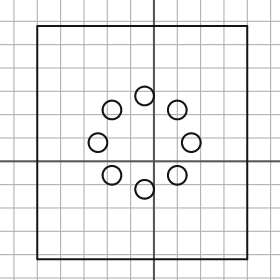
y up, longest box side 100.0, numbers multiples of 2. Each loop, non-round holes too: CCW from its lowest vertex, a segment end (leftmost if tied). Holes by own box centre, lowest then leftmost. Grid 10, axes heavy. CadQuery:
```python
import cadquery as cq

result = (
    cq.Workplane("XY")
    .moveTo(-50.0, -42.0)
    .lineTo(40.0, -42.0)
    .lineTo(40.0, 58.0)
    .lineTo(-50.0, 58.0)
    .close()
    .moveTo(-4.0, -12.0)
    .circle(4.0)
    .moveTo(-18.0, -6.0)
    .circle(4.0)
    .moveTo(10.0, -6.0)
    .circle(4.0)
    .moveTo(-24.0, 8.0)
    .circle(4.0)
    .moveTo(16.0, 8.0)
    .circle(4.0)
    .moveTo(-18.0, 22.0)
    .circle(4.0)
    .moveTo(10.0, 22.0)
    .circle(4.0)
    .moveTo(-4.0, 28.0)
    .circle(4.0)
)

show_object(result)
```